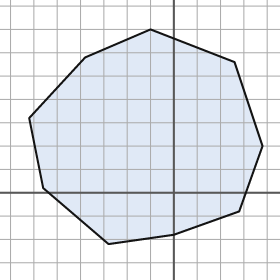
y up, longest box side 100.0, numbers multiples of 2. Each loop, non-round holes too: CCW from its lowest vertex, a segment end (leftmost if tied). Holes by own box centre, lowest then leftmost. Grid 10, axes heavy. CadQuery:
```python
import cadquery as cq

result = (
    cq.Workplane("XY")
    .moveTo(-28.0, -22.0)
    .lineTo(0.0, -18.0)
    .lineTo(28.0, -8.0)
    .lineTo(38.0, 20.0)
    .lineTo(26.0, 56.0)
    .lineTo(-10.0, 70.0)
    .lineTo(-38.0, 58.0)
    .lineTo(-62.0, 32.0)
    .lineTo(-56.0, 2.0)
    .close()
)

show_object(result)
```